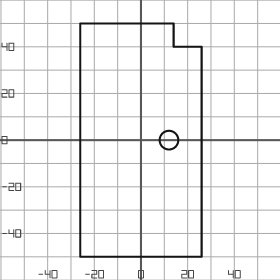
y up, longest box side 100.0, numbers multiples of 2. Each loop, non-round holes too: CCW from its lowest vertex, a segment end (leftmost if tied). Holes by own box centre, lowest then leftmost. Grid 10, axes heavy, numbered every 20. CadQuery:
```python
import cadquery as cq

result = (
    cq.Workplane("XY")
    .moveTo(-26.0, -50.0)
    .lineTo(26.0, -50.0)
    .lineTo(26.0, 40.0)
    .lineTo(14.0, 40.0)
    .lineTo(14.0, 50.0)
    .lineTo(-26.0, 50.0)
    .close()
    .moveTo(12.0, 0.0)
    .circle(4.0)
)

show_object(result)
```